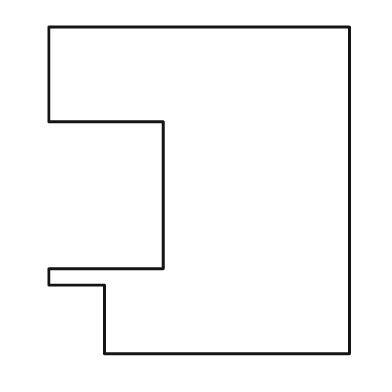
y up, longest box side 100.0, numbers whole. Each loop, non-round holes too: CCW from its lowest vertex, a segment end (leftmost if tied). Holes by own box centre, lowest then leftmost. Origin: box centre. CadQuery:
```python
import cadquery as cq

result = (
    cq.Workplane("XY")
    .moveTo(-29.0, -50.0)
    .lineTo(46.0, -50.0)
    .lineTo(46.0, 50.0)
    .lineTo(-46.0, 50.0)
    .lineTo(-46.0, 21.0)
    .lineTo(-11.0, 21.0)
    .lineTo(-11.0, -24.0)
    .lineTo(-46.0, -24.0)
    .lineTo(-46.0, -29.0)
    .lineTo(-29.0, -29.0)
    .close()
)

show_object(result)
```